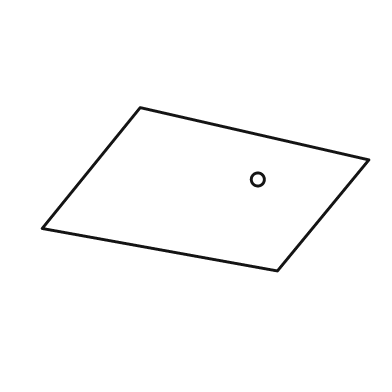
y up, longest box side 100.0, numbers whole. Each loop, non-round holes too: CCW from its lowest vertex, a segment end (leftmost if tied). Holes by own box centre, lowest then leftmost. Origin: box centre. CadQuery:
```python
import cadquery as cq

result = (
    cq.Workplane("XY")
    .moveTo(22.0, -25.0)
    .lineTo(50.0, 9.0)
    .lineTo(-20.0, 25.0)
    .lineTo(-50.0, -12.0)
    .close()
    .moveTo(16.0, 3.0)
    .circle(2.0)
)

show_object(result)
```